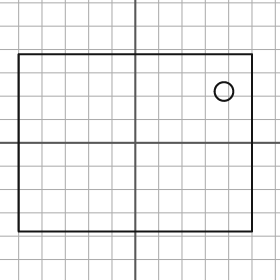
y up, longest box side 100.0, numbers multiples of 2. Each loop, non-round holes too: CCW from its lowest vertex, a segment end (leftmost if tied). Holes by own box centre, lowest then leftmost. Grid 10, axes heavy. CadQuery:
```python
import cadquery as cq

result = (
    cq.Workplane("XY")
    .moveTo(-50.0, -38.0)
    .lineTo(50.0, -38.0)
    .lineTo(50.0, 38.0)
    .lineTo(-50.0, 38.0)
    .close()
    .moveTo(38.0, 22.0)
    .circle(4.0)
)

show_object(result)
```